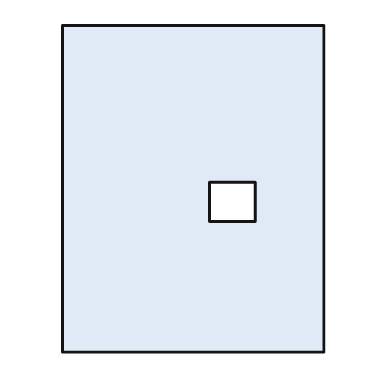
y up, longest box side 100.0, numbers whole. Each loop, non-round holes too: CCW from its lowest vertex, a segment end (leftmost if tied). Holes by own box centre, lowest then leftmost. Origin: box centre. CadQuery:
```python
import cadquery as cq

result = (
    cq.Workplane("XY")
    .moveTo(-40.0, -50.0)
    .lineTo(40.0, -50.0)
    .lineTo(40.0, 50.0)
    .lineTo(-40.0, 50.0)
    .close()
    .moveTo(5.0, -10.0)
    .lineTo(19.0, -10.0)
    .lineTo(19.0, 2.0)
    .lineTo(5.0, 2.0)
    .close()
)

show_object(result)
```